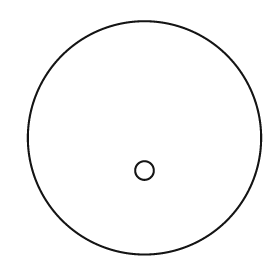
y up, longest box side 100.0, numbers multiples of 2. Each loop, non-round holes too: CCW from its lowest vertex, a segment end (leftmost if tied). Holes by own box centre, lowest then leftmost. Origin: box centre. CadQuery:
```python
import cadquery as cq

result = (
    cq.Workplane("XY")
    .moveTo(0.0, 0.0)
    .circle(50.0)
    .moveTo(0.0, -14.0)
    .circle(4.0)
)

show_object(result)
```